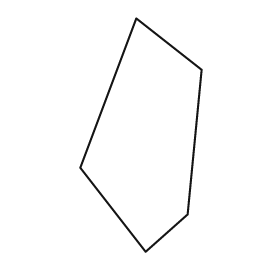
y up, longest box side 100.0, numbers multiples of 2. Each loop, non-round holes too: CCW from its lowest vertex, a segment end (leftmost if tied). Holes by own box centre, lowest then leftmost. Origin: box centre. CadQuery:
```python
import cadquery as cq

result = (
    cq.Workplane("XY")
    .moveTo(2.0, -50.0)
    .lineTo(20.0, -34.0)
    .lineTo(26.0, 28.0)
    .lineTo(-2.0, 50.0)
    .lineTo(-26.0, -14.0)
    .close()
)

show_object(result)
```